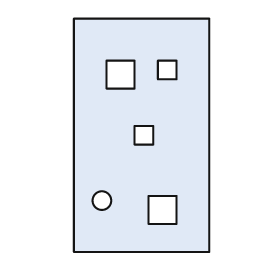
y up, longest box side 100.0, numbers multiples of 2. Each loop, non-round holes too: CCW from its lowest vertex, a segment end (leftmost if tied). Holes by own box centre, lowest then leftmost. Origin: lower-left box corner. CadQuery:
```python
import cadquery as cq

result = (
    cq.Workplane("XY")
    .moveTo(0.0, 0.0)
    .lineTo(58.0, 0.0)
    .lineTo(58.0, 100.0)
    .lineTo(0.0, 100.0)
    .close()
    .moveTo(32.0, 12.0)
    .lineTo(44.0, 12.0)
    .lineTo(44.0, 24.0)
    .lineTo(32.0, 24.0)
    .close()
    .moveTo(12.0, 22.0)
    .circle(4.0)
    .moveTo(26.0, 46.0)
    .lineTo(34.0, 46.0)
    .lineTo(34.0, 54.0)
    .lineTo(26.0, 54.0)
    .close()
    .moveTo(14.0, 70.0)
    .lineTo(26.0, 70.0)
    .lineTo(26.0, 82.0)
    .lineTo(14.0, 82.0)
    .close()
    .moveTo(36.0, 74.0)
    .lineTo(44.0, 74.0)
    .lineTo(44.0, 82.0)
    .lineTo(36.0, 82.0)
    .close()
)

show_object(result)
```